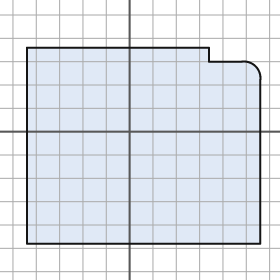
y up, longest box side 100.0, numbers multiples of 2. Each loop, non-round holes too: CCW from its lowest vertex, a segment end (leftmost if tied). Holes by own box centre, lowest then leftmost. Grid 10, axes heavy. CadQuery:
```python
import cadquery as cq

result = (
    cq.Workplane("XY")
    .moveTo(-44.0, -48.0)
    .lineTo(56.0, -48.0)
    .lineTo(56.0, 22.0)
    .threePointArc((54.0, 28.0), (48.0, 30.0))
    .lineTo(34.0, 30.0)
    .lineTo(34.0, 36.0)
    .lineTo(-44.0, 36.0)
    .close()
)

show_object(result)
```